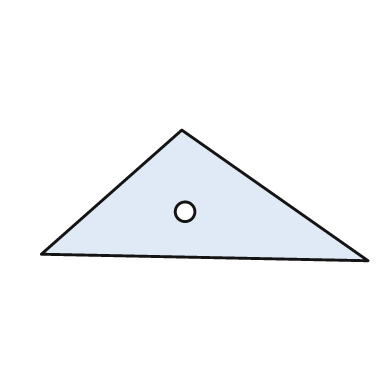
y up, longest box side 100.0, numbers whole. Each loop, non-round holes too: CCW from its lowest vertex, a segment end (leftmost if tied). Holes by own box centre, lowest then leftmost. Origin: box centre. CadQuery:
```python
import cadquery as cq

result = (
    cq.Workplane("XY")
    .moveTo(50.0, -20.0)
    .lineTo(-7.0, 20.0)
    .lineTo(-50.0, -18.0)
    .close()
    .moveTo(-6.0, -5.0)
    .circle(3.0)
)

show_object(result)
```